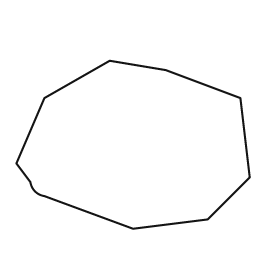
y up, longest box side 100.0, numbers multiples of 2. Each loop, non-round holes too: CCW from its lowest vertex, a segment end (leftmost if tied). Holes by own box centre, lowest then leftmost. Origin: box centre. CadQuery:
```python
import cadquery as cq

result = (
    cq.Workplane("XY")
    .moveTo(0.0, -36.0)
    .lineTo(32.0, -32.0)
    .lineTo(50.0, -14.0)
    .lineTo(46.0, 20.0)
    .lineTo(14.0, 32.0)
    .lineTo(-10.0, 36.0)
    .lineTo(-38.0, 20.0)
    .lineTo(-50.0, -8.0)
    .lineTo(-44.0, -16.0)
    .threePointArc((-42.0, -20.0), (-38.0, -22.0))
    .close()
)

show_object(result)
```